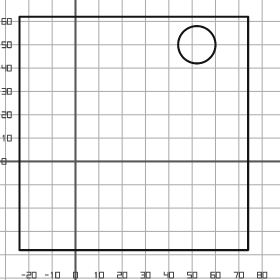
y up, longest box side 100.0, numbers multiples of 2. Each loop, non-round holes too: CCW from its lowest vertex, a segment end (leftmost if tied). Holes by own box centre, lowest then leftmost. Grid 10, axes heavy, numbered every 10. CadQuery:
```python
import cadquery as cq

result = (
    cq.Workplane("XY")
    .moveTo(-24.0, -38.0)
    .lineTo(74.0, -38.0)
    .lineTo(74.0, 62.0)
    .lineTo(-24.0, 62.0)
    .close()
    .moveTo(52.0, 50.0)
    .circle(8.0)
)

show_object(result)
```